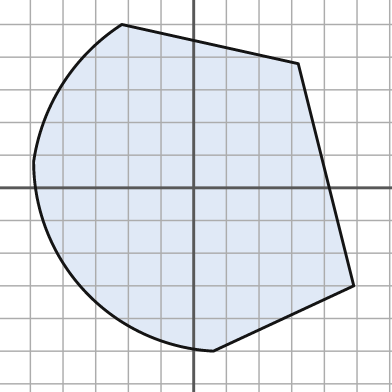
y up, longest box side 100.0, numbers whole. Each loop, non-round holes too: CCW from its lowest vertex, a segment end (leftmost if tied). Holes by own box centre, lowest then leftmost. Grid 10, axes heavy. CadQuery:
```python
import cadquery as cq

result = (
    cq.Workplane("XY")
    .moveTo(6.0, -50.0)
    .lineTo(49.0, -30.0)
    .lineTo(32.0, 38.0)
    .lineTo(-22.0, 50.0)
    .threePointArc((-40.0, 32.0), (-49.0, 8.0))
    .threePointArc((-33.0, -32.0), (6.0, -50.0))
    .close()
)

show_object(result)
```